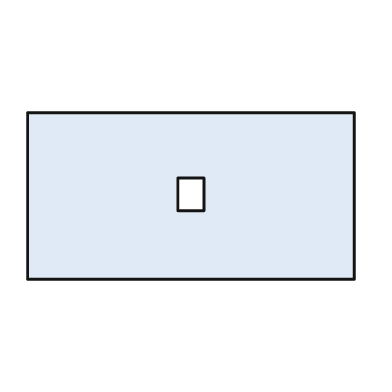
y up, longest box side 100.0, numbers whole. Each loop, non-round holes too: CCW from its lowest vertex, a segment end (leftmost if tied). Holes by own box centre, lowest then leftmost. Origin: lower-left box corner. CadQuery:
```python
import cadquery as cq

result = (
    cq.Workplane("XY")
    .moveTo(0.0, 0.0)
    .lineTo(100.0, 0.0)
    .lineTo(100.0, 51.0)
    .lineTo(0.0, 51.0)
    .close()
    .moveTo(46.0, 21.0)
    .lineTo(54.0, 21.0)
    .lineTo(54.0, 31.0)
    .lineTo(46.0, 31.0)
    .close()
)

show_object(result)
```